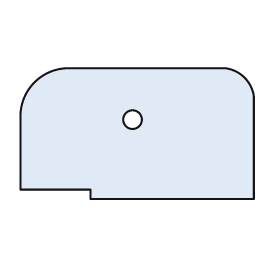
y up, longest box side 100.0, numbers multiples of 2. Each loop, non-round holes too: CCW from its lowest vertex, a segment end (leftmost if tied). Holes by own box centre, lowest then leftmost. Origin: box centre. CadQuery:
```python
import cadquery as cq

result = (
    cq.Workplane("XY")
    .moveTo(-20.0, -28.0)
    .lineTo(50.0, -28.0)
    .lineTo(50.0, 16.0)
    .threePointArc((46.0, 24.0), (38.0, 28.0))
    .lineTo(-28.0, 28.0)
    .threePointArc((-44.0, 22.0), (-50.0, 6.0))
    .lineTo(-50.0, -24.0)
    .lineTo(-20.0, -24.0)
    .close()
    .moveTo(-2.0, 6.0)
    .circle(4.0)
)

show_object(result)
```